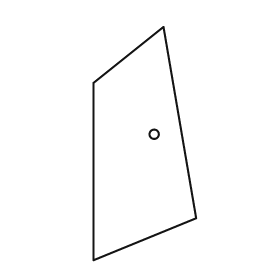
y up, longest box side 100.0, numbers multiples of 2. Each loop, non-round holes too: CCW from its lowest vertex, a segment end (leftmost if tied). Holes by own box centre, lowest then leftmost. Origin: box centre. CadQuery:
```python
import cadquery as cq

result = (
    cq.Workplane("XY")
    .moveTo(-22.0, -50.0)
    .lineTo(22.0, -32.0)
    .lineTo(8.0, 50.0)
    .lineTo(-22.0, 26.0)
    .close()
    .moveTo(4.0, 4.0)
    .circle(2.0)
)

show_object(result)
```